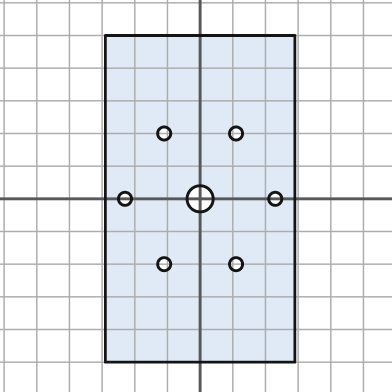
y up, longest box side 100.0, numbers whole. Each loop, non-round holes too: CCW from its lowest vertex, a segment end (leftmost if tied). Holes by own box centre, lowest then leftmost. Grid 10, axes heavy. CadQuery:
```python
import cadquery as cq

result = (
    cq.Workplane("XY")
    .moveTo(-29.0, -50.0)
    .lineTo(29.0, -50.0)
    .lineTo(29.0, 50.0)
    .lineTo(-29.0, 50.0)
    .close()
    .moveTo(-11.0, -20.0)
    .circle(2.0)
    .moveTo(11.0, -20.0)
    .circle(2.0)
    .moveTo(-23.0, 0.0)
    .circle(2.0)
    .moveTo(0.0, 0.0)
    .circle(4.0)
    .moveTo(23.0, 0.0)
    .circle(2.0)
    .moveTo(-11.0, 20.0)
    .circle(2.0)
    .moveTo(11.0, 20.0)
    .circle(2.0)
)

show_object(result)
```